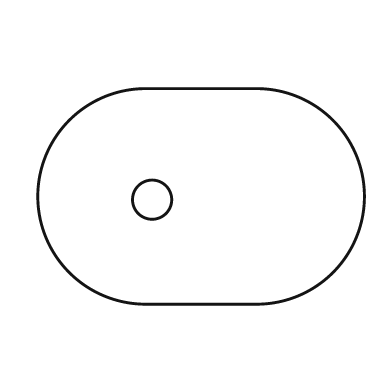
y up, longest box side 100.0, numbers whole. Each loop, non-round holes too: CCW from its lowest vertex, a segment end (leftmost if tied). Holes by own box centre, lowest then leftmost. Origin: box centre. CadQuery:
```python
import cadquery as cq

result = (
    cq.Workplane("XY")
    .moveTo(-17.0, -33.0)
    .lineTo(17.0, -33.0)
    .threePointArc((50.0, 0.0), (17.0, 33.0))
    .lineTo(-17.0, 33.0)
    .threePointArc((-50.0, 0.0), (-17.0, -33.0))
    .close()
    .moveTo(-15.0, -1.0)
    .circle(6.0)
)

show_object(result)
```